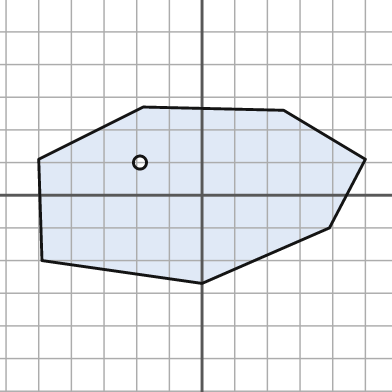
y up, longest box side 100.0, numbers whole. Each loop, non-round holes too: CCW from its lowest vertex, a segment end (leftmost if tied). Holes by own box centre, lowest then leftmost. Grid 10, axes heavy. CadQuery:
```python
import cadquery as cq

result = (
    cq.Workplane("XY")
    .moveTo(0.0, -27.0)
    .lineTo(39.0, -10.0)
    .lineTo(50.0, 11.0)
    .lineTo(25.0, 26.0)
    .lineTo(-18.0, 27.0)
    .lineTo(-50.0, 11.0)
    .lineTo(-49.0, -20.0)
    .close()
    .moveTo(-19.0, 10.0)
    .circle(2.0)
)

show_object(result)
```